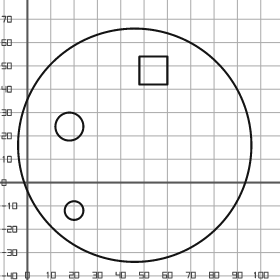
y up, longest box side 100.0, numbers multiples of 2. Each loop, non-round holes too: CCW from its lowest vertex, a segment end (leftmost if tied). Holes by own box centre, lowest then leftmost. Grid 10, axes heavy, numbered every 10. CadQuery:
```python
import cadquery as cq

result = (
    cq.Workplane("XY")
    .moveTo(46.0, 16.0)
    .circle(50.0)
    .moveTo(20.0, -12.0)
    .circle(4.0)
    .moveTo(18.0, 24.0)
    .circle(6.0)
    .moveTo(48.0, 42.0)
    .lineTo(60.0, 42.0)
    .lineTo(60.0, 54.0)
    .lineTo(48.0, 54.0)
    .close()
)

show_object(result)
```